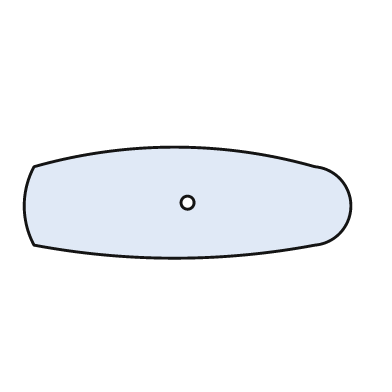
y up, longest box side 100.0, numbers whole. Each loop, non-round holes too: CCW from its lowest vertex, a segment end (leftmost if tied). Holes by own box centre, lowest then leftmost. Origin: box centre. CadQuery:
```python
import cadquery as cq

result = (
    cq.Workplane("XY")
    .moveTo(-47.0, -13.0)
    .threePointArc((-4.0, -17.0), (39.0, -13.0))
    .threePointArc((50.0, -1.0), (39.0, 11.0))
    .threePointArc((-4.0, 17.0), (-47.0, 11.0))
    .threePointArc((-50.0, -1.0), (-47.0, -13.0))
    .close()
    .moveTo(0.0, 0.0)
    .circle(2.0)
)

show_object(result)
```